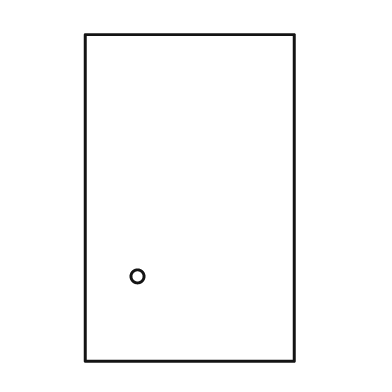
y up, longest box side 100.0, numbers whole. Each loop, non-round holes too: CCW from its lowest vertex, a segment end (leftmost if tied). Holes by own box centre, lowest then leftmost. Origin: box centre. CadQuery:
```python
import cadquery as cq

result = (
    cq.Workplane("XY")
    .moveTo(-32.0, -50.0)
    .lineTo(32.0, -50.0)
    .lineTo(32.0, 50.0)
    .lineTo(-32.0, 50.0)
    .close()
    .moveTo(-16.0, -24.0)
    .circle(2.0)
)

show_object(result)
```